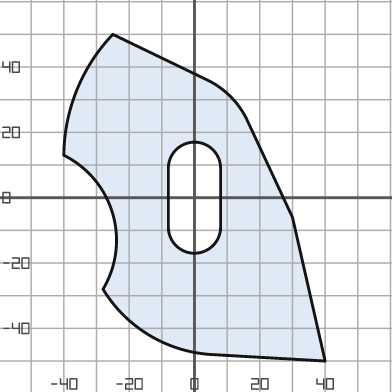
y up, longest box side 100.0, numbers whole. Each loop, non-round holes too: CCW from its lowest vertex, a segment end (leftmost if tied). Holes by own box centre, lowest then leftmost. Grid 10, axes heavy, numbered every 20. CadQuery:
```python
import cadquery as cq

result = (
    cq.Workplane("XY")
    .moveTo(40.0, -50.0)
    .lineTo(30.0, -6.0)
    .lineTo(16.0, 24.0)
    .threePointArc((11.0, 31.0), (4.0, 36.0))
    .lineTo(-25.0, 50.0)
    .threePointArc((-36.0, 33.0), (-40.0, 13.0))
    .threePointArc((-25.0, -5.0), (-28.0, -28.0))
    .threePointArc((-14.0, -42.0), (5.0, -48.0))
    .close()
    .moveTo(-8.0, -9.0)
    .threePointArc((0.0, -17.0), (8.0, -9.0))
    .lineTo(8.0, 9.0)
    .threePointArc((0.0, 17.0), (-8.0, 9.0))
    .close()
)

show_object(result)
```